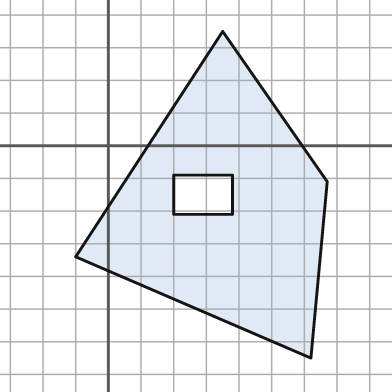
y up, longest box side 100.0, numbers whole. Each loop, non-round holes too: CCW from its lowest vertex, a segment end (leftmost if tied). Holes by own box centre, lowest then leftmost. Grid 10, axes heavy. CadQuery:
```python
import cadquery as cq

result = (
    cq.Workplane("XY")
    .moveTo(62.0, -65.0)
    .lineTo(67.0, -11.0)
    .lineTo(35.0, 35.0)
    .lineTo(-10.0, -34.0)
    .close()
    .moveTo(20.0, -21.0)
    .lineTo(38.0, -21.0)
    .lineTo(38.0, -9.0)
    .lineTo(20.0, -9.0)
    .close()
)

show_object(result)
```